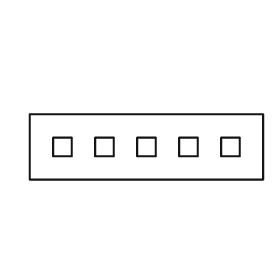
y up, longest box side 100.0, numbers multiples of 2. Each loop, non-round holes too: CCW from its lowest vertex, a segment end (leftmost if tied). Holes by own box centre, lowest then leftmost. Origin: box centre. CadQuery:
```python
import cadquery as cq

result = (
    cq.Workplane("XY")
    .moveTo(-50.0, -14.0)
    .lineTo(50.0, -14.0)
    .lineTo(50.0, 14.0)
    .lineTo(-50.0, 14.0)
    .close()
    .moveTo(-40.0, -4.0)
    .lineTo(-32.0, -4.0)
    .lineTo(-32.0, 4.0)
    .lineTo(-40.0, 4.0)
    .close()
    .moveTo(-22.0, -4.0)
    .lineTo(-14.0, -4.0)
    .lineTo(-14.0, 4.0)
    .lineTo(-22.0, 4.0)
    .close()
    .moveTo(-4.0, -4.0)
    .lineTo(4.0, -4.0)
    .lineTo(4.0, 4.0)
    .lineTo(-4.0, 4.0)
    .close()
    .moveTo(14.0, -4.0)
    .lineTo(22.0, -4.0)
    .lineTo(22.0, 4.0)
    .lineTo(14.0, 4.0)
    .close()
    .moveTo(32.0, -4.0)
    .lineTo(40.0, -4.0)
    .lineTo(40.0, 4.0)
    .lineTo(32.0, 4.0)
    .close()
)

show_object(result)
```